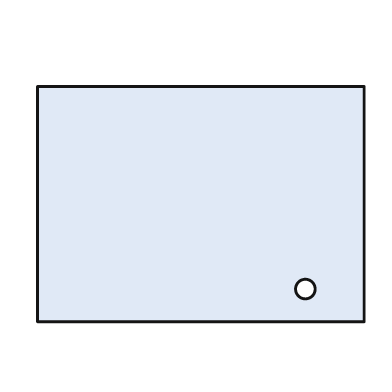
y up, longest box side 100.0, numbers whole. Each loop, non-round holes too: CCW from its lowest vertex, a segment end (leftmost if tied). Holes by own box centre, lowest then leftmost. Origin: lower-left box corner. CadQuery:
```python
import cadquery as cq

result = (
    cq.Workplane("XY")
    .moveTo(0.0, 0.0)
    .lineTo(100.0, 0.0)
    .lineTo(100.0, 72.0)
    .lineTo(0.0, 72.0)
    .close()
    .moveTo(82.0, 10.0)
    .circle(3.0)
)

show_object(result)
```